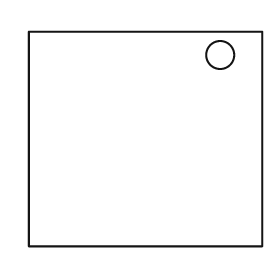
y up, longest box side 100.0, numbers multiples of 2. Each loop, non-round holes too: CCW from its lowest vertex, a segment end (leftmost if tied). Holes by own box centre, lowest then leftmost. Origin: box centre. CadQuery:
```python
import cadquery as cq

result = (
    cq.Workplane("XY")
    .moveTo(-50.0, -46.0)
    .lineTo(50.0, -46.0)
    .lineTo(50.0, 46.0)
    .lineTo(-50.0, 46.0)
    .close()
    .moveTo(32.0, 36.0)
    .circle(6.0)
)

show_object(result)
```